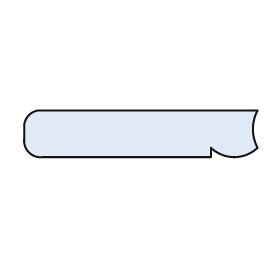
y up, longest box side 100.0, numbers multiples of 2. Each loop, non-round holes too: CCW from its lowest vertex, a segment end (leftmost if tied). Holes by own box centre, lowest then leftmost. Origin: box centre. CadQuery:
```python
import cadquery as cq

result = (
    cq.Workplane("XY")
    .moveTo(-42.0, -10.0)
    .lineTo(30.0, -10.0)
    .lineTo(30.0, -6.0)
    .threePointArc((40.0, -10.0), (50.0, -6.0))
    .threePointArc((48.0, 2.0), (50.0, 10.0))
    .lineTo(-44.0, 10.0)
    .threePointArc((-48.0, 8.0), (-50.0, 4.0))
    .lineTo(-50.0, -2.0)
    .threePointArc((-48.0, -8.0), (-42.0, -10.0))
    .close()
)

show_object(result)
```